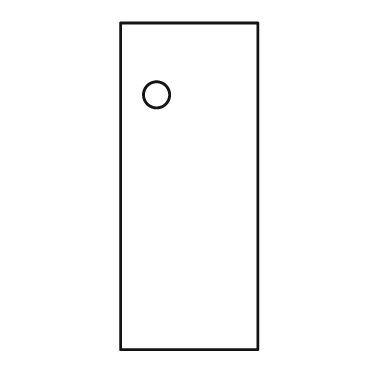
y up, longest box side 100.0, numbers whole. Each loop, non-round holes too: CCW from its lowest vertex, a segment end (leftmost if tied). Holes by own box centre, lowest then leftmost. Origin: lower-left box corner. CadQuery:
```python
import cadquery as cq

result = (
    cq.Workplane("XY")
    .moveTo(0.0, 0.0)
    .lineTo(42.0, 0.0)
    .lineTo(42.0, 100.0)
    .lineTo(0.0, 100.0)
    .close()
    .moveTo(11.0, 78.0)
    .circle(4.0)
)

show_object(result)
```